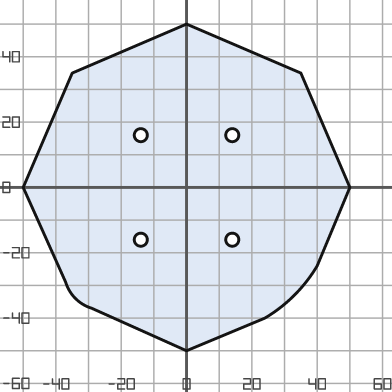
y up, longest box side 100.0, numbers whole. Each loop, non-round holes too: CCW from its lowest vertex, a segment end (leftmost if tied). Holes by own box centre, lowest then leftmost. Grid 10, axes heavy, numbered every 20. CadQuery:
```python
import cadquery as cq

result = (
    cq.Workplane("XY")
    .moveTo(0.0, -50.0)
    .lineTo(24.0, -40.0)
    .threePointArc((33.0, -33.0), (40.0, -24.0))
    .lineTo(50.0, 0.0)
    .lineTo(35.0, 35.0)
    .lineTo(0.0, 50.0)
    .lineTo(-35.0, 35.0)
    .lineTo(-50.0, 0.0)
    .lineTo(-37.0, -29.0)
    .threePointArc((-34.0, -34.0), (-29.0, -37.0))
    .close()
    .moveTo(-14.0, -16.0)
    .circle(2.0)
    .moveTo(14.0, -16.0)
    .circle(2.0)
    .moveTo(-14.0, 16.0)
    .circle(2.0)
    .moveTo(14.0, 16.0)
    .circle(2.0)
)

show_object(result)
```